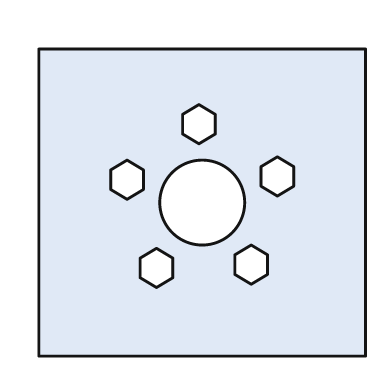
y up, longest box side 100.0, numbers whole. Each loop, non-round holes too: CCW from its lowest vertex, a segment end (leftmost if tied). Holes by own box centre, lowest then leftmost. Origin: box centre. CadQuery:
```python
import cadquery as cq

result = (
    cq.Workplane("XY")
    .moveTo(-50.0, -47.0)
    .lineTo(50.0, -47.0)
    .lineTo(50.0, 47.0)
    .lineTo(-50.0, 47.0)
    .close()
    .moveTo(-14.0, -26.0)
    .lineTo(-9.0, -23.0)
    .lineTo(-9.0, -17.0)
    .lineTo(-14.0, -14.0)
    .lineTo(-19.0, -17.0)
    .lineTo(-19.0, -23.0)
    .close()
    .moveTo(15.0, -25.0)
    .lineTo(20.0, -22.0)
    .lineTo(20.0, -16.0)
    .lineTo(15.0, -13.0)
    .lineTo(10.0, -16.0)
    .lineTo(10.0, -22.0)
    .close()
    .moveTo(0.0, 0.0)
    .circle(13.0)
    .moveTo(-23.0, 1.0)
    .lineTo(-18.0, 4.0)
    .lineTo(-18.0, 10.0)
    .lineTo(-23.0, 13.0)
    .lineTo(-28.0, 10.0)
    .lineTo(-28.0, 4.0)
    .close()
    .moveTo(23.0, 2.0)
    .lineTo(28.0, 5.0)
    .lineTo(28.0, 11.0)
    .lineTo(23.0, 14.0)
    .lineTo(18.0, 11.0)
    .lineTo(18.0, 5.0)
    .close()
    .moveTo(-1.0, 18.0)
    .lineTo(4.0, 21.0)
    .lineTo(4.0, 27.0)
    .lineTo(-1.0, 30.0)
    .lineTo(-6.0, 27.0)
    .lineTo(-6.0, 21.0)
    .close()
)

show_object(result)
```